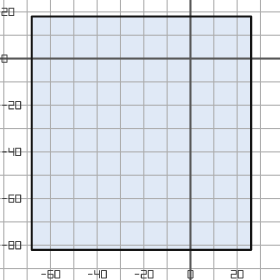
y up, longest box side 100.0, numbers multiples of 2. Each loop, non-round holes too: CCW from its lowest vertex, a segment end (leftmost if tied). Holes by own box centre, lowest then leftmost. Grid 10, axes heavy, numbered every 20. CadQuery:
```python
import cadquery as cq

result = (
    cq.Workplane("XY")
    .moveTo(-68.0, -82.0)
    .lineTo(26.0, -82.0)
    .lineTo(26.0, 18.0)
    .lineTo(-68.0, 18.0)
    .close()
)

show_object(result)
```